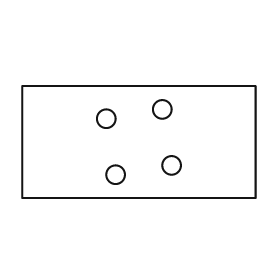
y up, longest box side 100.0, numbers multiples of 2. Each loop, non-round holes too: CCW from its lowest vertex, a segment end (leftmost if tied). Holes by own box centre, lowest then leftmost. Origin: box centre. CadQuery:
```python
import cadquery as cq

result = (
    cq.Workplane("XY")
    .moveTo(-50.0, -24.0)
    .lineTo(50.0, -24.0)
    .lineTo(50.0, 24.0)
    .lineTo(-50.0, 24.0)
    .close()
    .moveTo(-10.0, -14.0)
    .circle(4.0)
    .moveTo(14.0, -10.0)
    .circle(4.0)
    .moveTo(-14.0, 10.0)
    .circle(4.0)
    .moveTo(10.0, 14.0)
    .circle(4.0)
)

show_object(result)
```